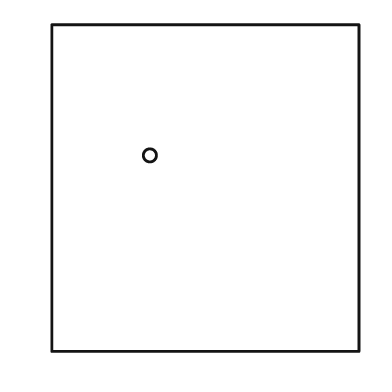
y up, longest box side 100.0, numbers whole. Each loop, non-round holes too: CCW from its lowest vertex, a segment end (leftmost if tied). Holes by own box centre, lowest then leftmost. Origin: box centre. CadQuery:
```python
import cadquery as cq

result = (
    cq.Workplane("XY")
    .moveTo(-47.0, -50.0)
    .lineTo(47.0, -50.0)
    .lineTo(47.0, 50.0)
    .lineTo(-47.0, 50.0)
    .close()
    .moveTo(-17.0, 10.0)
    .circle(2.0)
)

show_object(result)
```